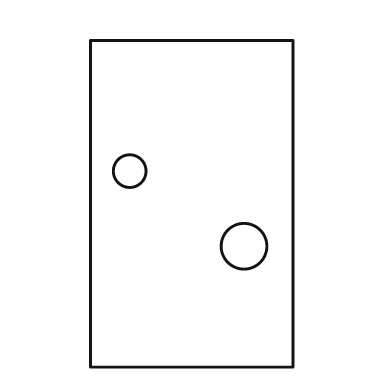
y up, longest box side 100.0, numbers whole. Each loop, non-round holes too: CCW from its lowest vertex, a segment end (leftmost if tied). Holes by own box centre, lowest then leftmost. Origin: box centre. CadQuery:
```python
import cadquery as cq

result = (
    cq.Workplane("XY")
    .moveTo(-31.0, -50.0)
    .lineTo(31.0, -50.0)
    .lineTo(31.0, 50.0)
    .lineTo(-31.0, 50.0)
    .close()
    .moveTo(16.0, -13.0)
    .circle(7.0)
    .moveTo(-19.0, 10.0)
    .circle(5.0)
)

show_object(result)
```